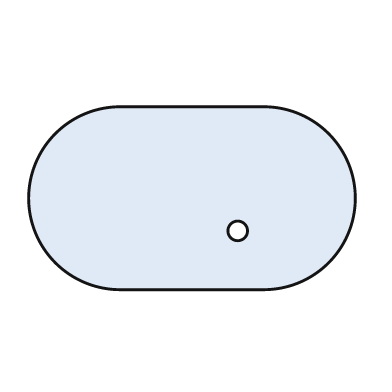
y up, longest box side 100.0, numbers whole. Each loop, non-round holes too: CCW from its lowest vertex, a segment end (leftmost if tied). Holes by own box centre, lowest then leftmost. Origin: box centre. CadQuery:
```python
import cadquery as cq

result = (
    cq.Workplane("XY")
    .moveTo(-22.0, -28.0)
    .lineTo(22.0, -28.0)
    .threePointArc((50.0, 0.0), (22.0, 28.0))
    .lineTo(-22.0, 28.0)
    .threePointArc((-50.0, 0.0), (-22.0, -28.0))
    .close()
    .moveTo(14.0, -10.0)
    .circle(3.0)
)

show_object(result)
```